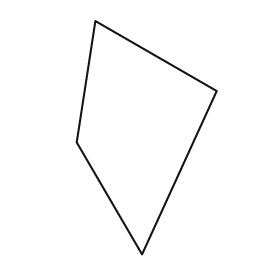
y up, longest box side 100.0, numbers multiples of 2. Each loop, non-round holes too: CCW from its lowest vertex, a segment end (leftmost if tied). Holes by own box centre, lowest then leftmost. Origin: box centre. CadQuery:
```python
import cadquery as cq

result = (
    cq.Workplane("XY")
    .moveTo(-2.0, -50.0)
    .lineTo(30.0, 20.0)
    .lineTo(-22.0, 50.0)
    .lineTo(-30.0, -2.0)
    .close()
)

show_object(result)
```